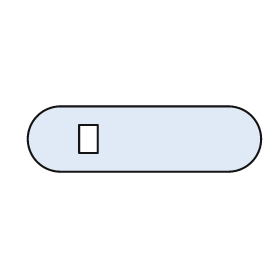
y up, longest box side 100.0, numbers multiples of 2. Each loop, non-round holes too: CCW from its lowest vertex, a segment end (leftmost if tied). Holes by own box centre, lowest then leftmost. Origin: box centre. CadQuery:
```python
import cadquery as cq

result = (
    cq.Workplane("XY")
    .moveTo(-36.0, -14.0)
    .lineTo(36.0, -14.0)
    .threePointArc((50.0, 0.0), (36.0, 14.0))
    .lineTo(-36.0, 14.0)
    .threePointArc((-50.0, 0.0), (-36.0, -14.0))
    .close()
    .moveTo(-28.0, -6.0)
    .lineTo(-20.0, -6.0)
    .lineTo(-20.0, 6.0)
    .lineTo(-28.0, 6.0)
    .close()
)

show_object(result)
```